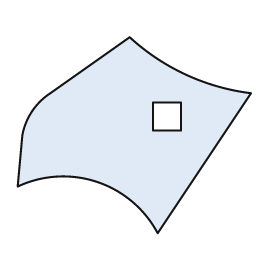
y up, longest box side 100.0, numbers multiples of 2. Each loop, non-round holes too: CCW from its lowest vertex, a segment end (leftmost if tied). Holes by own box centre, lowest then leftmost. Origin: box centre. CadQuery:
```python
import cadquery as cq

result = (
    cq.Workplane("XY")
    .moveTo(10.0, -42.0)
    .lineTo(50.0, 18.0)
    .threePointArc((22.0, 26.0), (-2.0, 42.0))
    .lineTo(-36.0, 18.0)
    .threePointArc((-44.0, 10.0), (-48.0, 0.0))
    .lineTo(-50.0, -22.0)
    .threePointArc((-16.0, -20.0), (10.0, -42.0))
    .close()
    .moveTo(8.0, 2.0)
    .lineTo(20.0, 2.0)
    .lineTo(20.0, 14.0)
    .lineTo(8.0, 14.0)
    .close()
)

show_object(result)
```